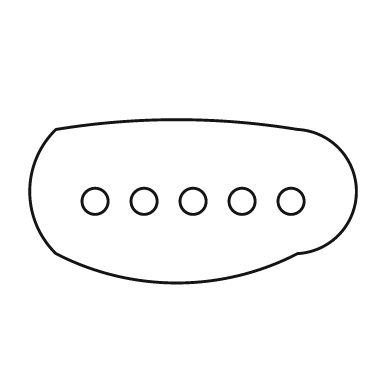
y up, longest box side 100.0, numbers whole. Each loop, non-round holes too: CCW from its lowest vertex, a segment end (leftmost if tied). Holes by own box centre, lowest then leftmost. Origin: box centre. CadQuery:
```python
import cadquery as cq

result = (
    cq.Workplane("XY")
    .moveTo(-42.0, -16.0)
    .threePointArc((-5.0, -25.0), (32.0, -16.0))
    .threePointArc((50.0, 3.0), (32.0, 22.0))
    .threePointArc((-5.0, 25.0), (-42.0, 22.0))
    .threePointArc((-50.0, 3.0), (-42.0, -16.0))
    .close()
    .moveTo(-30.0, 0.0)
    .circle(4.0)
    .moveTo(-15.0, 0.0)
    .circle(4.0)
    .moveTo(0.0, 0.0)
    .circle(4.0)
    .moveTo(15.0, 0.0)
    .circle(4.0)
    .moveTo(30.0, 0.0)
    .circle(4.0)
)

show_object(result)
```